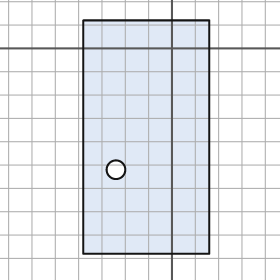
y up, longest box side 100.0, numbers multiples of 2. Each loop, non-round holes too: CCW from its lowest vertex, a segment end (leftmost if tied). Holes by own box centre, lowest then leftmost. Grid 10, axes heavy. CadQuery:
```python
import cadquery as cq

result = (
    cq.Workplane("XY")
    .moveTo(-38.0, -88.0)
    .lineTo(16.0, -88.0)
    .lineTo(16.0, 12.0)
    .lineTo(-38.0, 12.0)
    .close()
    .moveTo(-24.0, -52.0)
    .circle(4.0)
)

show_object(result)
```